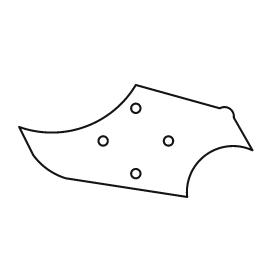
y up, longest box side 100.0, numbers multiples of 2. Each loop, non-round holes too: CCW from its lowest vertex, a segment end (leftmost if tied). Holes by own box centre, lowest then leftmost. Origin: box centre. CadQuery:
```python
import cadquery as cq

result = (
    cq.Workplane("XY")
    .moveTo(22.0, -24.0)
    .threePointArc((30.0, -6.0), (50.0, -4.0))
    .lineTo(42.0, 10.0)
    .threePointArc((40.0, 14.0), (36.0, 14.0))
    .lineTo(0.0, 24.0)
    .threePointArc((-22.0, 6.0), (-50.0, 6.0))
    .lineTo(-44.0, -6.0)
    .threePointArc((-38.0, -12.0), (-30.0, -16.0))
    .close()
    .moveTo(0.0, -14.0)
    .circle(2.0)
    .moveTo(-14.0, 0.0)
    .circle(2.0)
    .moveTo(14.0, 0.0)
    .circle(2.0)
    .moveTo(0.0, 14.0)
    .circle(2.0)
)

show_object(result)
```